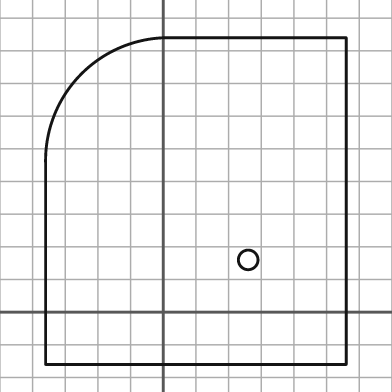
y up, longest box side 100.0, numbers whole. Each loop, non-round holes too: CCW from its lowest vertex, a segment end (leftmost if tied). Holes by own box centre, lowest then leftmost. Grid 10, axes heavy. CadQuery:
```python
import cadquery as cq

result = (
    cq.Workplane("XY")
    .moveTo(-36.0, -16.0)
    .lineTo(56.0, -16.0)
    .lineTo(56.0, 84.0)
    .lineTo(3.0, 84.0)
    .threePointArc((-25.0, 73.0), (-36.0, 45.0))
    .close()
    .moveTo(26.0, 16.0)
    .circle(3.0)
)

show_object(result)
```